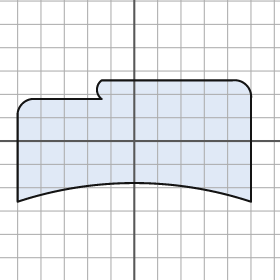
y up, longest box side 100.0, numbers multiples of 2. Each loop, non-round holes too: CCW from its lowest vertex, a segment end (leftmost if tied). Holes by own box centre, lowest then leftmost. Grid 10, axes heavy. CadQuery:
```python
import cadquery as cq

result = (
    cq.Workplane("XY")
    .moveTo(-50.0, -26.0)
    .threePointArc((0.0, -18.0), (50.0, -26.0))
    .lineTo(50.0, 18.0)
    .threePointArc((48.0, 24.0), (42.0, 26.0))
    .lineTo(-14.0, 26.0)
    .threePointArc((-16.0, 22.0), (-14.0, 18.0))
    .lineTo(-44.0, 18.0)
    .threePointArc((-48.0, 16.0), (-50.0, 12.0))
    .close()
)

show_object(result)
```